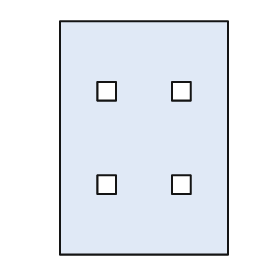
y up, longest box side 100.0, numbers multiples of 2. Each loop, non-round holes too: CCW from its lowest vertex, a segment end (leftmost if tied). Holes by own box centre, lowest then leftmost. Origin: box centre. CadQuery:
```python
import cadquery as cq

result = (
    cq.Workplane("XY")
    .moveTo(-36.0, -50.0)
    .lineTo(36.0, -50.0)
    .lineTo(36.0, 50.0)
    .lineTo(-36.0, 50.0)
    .close()
    .moveTo(-20.0, -24.0)
    .lineTo(-12.0, -24.0)
    .lineTo(-12.0, -16.0)
    .lineTo(-20.0, -16.0)
    .close()
    .moveTo(12.0, -24.0)
    .lineTo(20.0, -24.0)
    .lineTo(20.0, -16.0)
    .lineTo(12.0, -16.0)
    .close()
    .moveTo(-20.0, 16.0)
    .lineTo(-12.0, 16.0)
    .lineTo(-12.0, 24.0)
    .lineTo(-20.0, 24.0)
    .close()
    .moveTo(12.0, 16.0)
    .lineTo(20.0, 16.0)
    .lineTo(20.0, 24.0)
    .lineTo(12.0, 24.0)
    .close()
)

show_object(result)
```